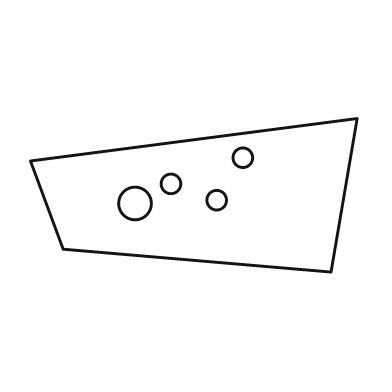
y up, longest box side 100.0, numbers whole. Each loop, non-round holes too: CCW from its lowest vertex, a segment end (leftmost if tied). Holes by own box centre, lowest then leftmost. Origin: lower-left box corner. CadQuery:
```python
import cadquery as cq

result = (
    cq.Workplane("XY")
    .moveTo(92.0, 0.0)
    .lineTo(100.0, 47.0)
    .lineTo(0.0, 34.0)
    .lineTo(10.0, 7.0)
    .close()
    .moveTo(32.0, 21.0)
    .circle(5.0)
    .moveTo(57.0, 22.0)
    .circle(3.0)
    .moveTo(43.0, 27.0)
    .circle(3.0)
    .moveTo(65.0, 35.0)
    .circle(3.0)
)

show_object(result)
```